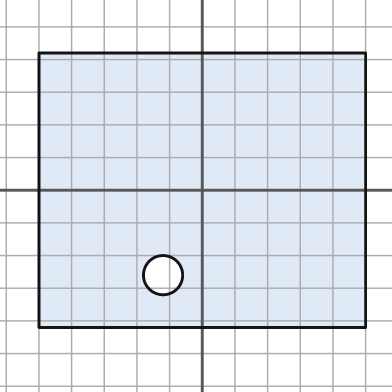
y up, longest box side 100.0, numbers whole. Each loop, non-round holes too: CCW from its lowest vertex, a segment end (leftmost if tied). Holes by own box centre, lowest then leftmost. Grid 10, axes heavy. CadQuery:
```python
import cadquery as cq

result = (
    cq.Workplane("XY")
    .moveTo(-50.0, -42.0)
    .lineTo(50.0, -42.0)
    .lineTo(50.0, 42.0)
    .lineTo(-50.0, 42.0)
    .close()
    .moveTo(-12.0, -26.0)
    .circle(6.0)
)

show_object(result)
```